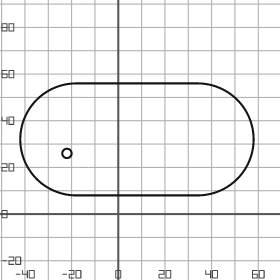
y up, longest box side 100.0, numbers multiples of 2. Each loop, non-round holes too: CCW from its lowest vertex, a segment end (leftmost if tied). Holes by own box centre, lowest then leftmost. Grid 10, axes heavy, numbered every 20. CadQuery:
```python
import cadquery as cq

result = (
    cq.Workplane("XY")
    .moveTo(-18.0, 8.0)
    .lineTo(34.0, 8.0)
    .threePointArc((58.0, 32.0), (34.0, 56.0))
    .lineTo(-18.0, 56.0)
    .threePointArc((-42.0, 32.0), (-18.0, 8.0))
    .close()
    .moveTo(-22.0, 26.0)
    .circle(2.0)
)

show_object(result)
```